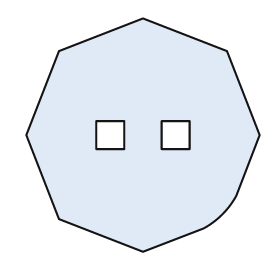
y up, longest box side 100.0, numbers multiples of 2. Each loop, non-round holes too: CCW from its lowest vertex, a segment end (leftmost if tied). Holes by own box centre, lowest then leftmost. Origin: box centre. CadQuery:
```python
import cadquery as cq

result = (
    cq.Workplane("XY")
    .moveTo(0.0, -50.0)
    .lineTo(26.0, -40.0)
    .threePointArc((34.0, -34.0), (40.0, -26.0))
    .lineTo(50.0, 0.0)
    .lineTo(36.0, 36.0)
    .lineTo(0.0, 50.0)
    .lineTo(-36.0, 36.0)
    .lineTo(-50.0, 0.0)
    .lineTo(-36.0, -36.0)
    .close()
    .moveTo(-20.0, -6.0)
    .lineTo(-8.0, -6.0)
    .lineTo(-8.0, 6.0)
    .lineTo(-20.0, 6.0)
    .close()
    .moveTo(8.0, -6.0)
    .lineTo(20.0, -6.0)
    .lineTo(20.0, 6.0)
    .lineTo(8.0, 6.0)
    .close()
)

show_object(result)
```